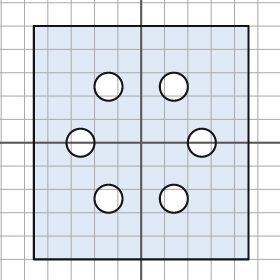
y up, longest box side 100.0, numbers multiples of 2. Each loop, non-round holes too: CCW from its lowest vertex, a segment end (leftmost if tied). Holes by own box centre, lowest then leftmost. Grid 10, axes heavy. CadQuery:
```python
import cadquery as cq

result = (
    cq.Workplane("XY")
    .moveTo(-46.0, -50.0)
    .lineTo(46.0, -50.0)
    .lineTo(46.0, 50.0)
    .lineTo(-46.0, 50.0)
    .close()
    .moveTo(-14.0, -24.0)
    .circle(6.0)
    .moveTo(14.0, -24.0)
    .circle(6.0)
    .moveTo(-26.0, 0.0)
    .circle(6.0)
    .moveTo(26.0, 0.0)
    .circle(6.0)
    .moveTo(-14.0, 24.0)
    .circle(6.0)
    .moveTo(14.0, 24.0)
    .circle(6.0)
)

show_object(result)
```